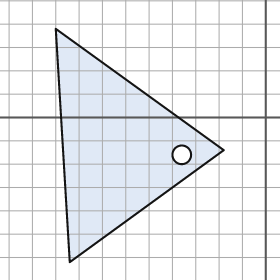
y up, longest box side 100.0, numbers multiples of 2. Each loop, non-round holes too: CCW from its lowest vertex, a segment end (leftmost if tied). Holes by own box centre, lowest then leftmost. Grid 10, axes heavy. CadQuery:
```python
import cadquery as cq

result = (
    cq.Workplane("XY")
    .moveTo(-84.0, -62.0)
    .lineTo(-18.0, -14.0)
    .lineTo(-90.0, 38.0)
    .close()
    .moveTo(-36.0, -16.0)
    .circle(4.0)
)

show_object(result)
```